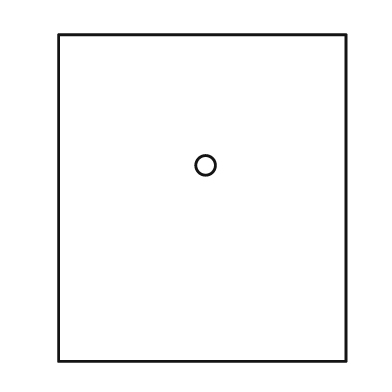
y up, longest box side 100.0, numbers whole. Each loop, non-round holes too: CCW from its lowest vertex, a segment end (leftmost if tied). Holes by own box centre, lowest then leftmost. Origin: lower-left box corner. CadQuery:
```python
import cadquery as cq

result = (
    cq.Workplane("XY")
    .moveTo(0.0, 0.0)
    .lineTo(88.0, 0.0)
    .lineTo(88.0, 100.0)
    .lineTo(0.0, 100.0)
    .close()
    .moveTo(45.0, 60.0)
    .circle(3.0)
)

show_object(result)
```